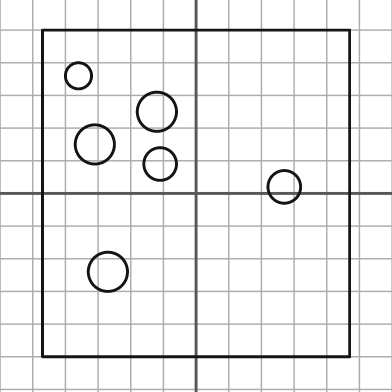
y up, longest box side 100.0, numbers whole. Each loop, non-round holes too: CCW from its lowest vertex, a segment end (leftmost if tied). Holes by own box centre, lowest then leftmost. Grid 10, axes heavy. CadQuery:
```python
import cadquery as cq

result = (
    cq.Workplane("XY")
    .moveTo(-47.0, -50.0)
    .lineTo(47.0, -50.0)
    .lineTo(47.0, 50.0)
    .lineTo(-47.0, 50.0)
    .close()
    .moveTo(-27.0, -24.0)
    .circle(6.0)
    .moveTo(27.0, 2.0)
    .circle(5.0)
    .moveTo(-11.0, 9.0)
    .circle(5.0)
    .moveTo(-31.0, 15.0)
    .circle(6.0)
    .moveTo(-12.0, 25.0)
    .circle(6.0)
    .moveTo(-36.0, 36.0)
    .circle(4.0)
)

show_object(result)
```